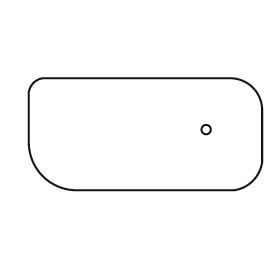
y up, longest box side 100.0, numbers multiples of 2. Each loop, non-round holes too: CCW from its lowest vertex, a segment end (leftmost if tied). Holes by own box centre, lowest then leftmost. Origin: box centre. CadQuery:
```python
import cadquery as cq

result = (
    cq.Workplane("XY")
    .moveTo(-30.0, -24.0)
    .lineTo(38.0, -24.0)
    .threePointArc((46.0, -20.0), (50.0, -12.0))
    .lineTo(50.0, 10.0)
    .threePointArc((46.0, 20.0), (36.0, 24.0))
    .lineTo(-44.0, 24.0)
    .threePointArc((-48.0, 22.0), (-50.0, 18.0))
    .lineTo(-50.0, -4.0)
    .threePointArc((-44.0, -18.0), (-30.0, -24.0))
    .close()
    .moveTo(26.0, 2.0)
    .circle(2.0)
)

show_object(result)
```